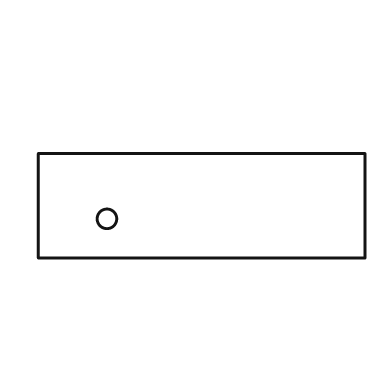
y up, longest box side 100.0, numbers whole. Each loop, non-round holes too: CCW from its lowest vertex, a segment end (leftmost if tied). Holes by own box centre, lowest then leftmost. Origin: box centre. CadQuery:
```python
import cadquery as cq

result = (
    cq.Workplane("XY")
    .moveTo(-50.0, -16.0)
    .lineTo(50.0, -16.0)
    .lineTo(50.0, 16.0)
    .lineTo(-50.0, 16.0)
    .close()
    .moveTo(-29.0, -4.0)
    .circle(3.0)
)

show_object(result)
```